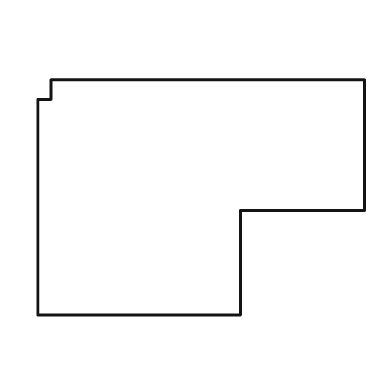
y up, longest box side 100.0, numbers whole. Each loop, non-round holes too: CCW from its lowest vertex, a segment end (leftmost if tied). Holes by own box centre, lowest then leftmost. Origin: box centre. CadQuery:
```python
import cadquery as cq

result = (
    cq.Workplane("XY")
    .moveTo(-50.0, -36.0)
    .lineTo(12.0, -36.0)
    .lineTo(12.0, -4.0)
    .lineTo(50.0, -4.0)
    .lineTo(50.0, 36.0)
    .lineTo(-46.0, 36.0)
    .lineTo(-46.0, 30.0)
    .lineTo(-50.0, 30.0)
    .close()
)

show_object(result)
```